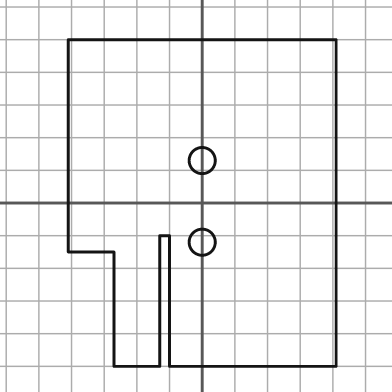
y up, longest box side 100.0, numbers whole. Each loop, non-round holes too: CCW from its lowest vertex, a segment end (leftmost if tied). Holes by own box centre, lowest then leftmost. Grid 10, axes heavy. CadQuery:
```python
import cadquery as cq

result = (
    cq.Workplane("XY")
    .moveTo(-27.0, -50.0)
    .lineTo(-13.0, -50.0)
    .lineTo(-13.0, -10.0)
    .lineTo(-10.0, -10.0)
    .lineTo(-10.0, -50.0)
    .lineTo(41.0, -50.0)
    .lineTo(41.0, 50.0)
    .lineTo(-41.0, 50.0)
    .lineTo(-41.0, -15.0)
    .lineTo(-27.0, -15.0)
    .close()
    .moveTo(0.0, -12.0)
    .circle(4.0)
    .moveTo(0.0, 13.0)
    .circle(4.0)
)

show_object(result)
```